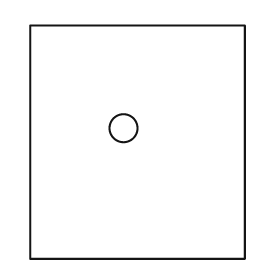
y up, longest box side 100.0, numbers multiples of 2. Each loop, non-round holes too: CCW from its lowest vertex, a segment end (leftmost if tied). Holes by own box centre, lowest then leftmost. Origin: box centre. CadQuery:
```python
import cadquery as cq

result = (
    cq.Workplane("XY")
    .moveTo(-46.0, -50.0)
    .lineTo(46.0, -50.0)
    .lineTo(46.0, 50.0)
    .lineTo(-46.0, 50.0)
    .close()
    .moveTo(-6.0, 6.0)
    .circle(6.0)
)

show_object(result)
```